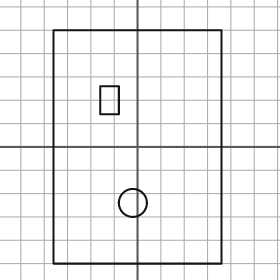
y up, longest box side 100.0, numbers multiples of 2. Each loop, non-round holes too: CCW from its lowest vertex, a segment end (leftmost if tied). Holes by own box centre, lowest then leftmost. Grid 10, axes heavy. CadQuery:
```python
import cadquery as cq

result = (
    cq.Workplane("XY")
    .moveTo(-36.0, -50.0)
    .lineTo(36.0, -50.0)
    .lineTo(36.0, 50.0)
    .lineTo(-36.0, 50.0)
    .close()
    .moveTo(-2.0, -24.0)
    .circle(6.0)
    .moveTo(-16.0, 14.0)
    .lineTo(-8.0, 14.0)
    .lineTo(-8.0, 26.0)
    .lineTo(-16.0, 26.0)
    .close()
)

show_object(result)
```